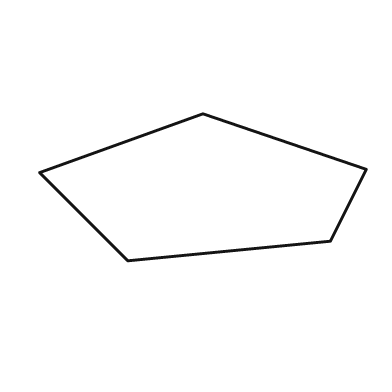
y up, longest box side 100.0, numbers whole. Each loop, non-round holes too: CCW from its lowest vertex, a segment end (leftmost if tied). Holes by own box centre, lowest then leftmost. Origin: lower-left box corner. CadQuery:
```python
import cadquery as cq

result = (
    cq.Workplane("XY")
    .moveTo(27.0, 0.0)
    .lineTo(89.0, 6.0)
    .lineTo(100.0, 28.0)
    .lineTo(50.0, 45.0)
    .lineTo(0.0, 27.0)
    .close()
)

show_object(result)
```